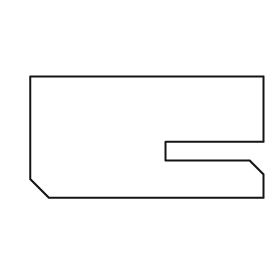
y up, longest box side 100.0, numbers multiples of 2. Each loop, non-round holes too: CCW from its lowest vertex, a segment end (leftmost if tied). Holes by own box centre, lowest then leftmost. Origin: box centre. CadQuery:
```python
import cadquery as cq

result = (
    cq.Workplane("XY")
    .moveTo(-42.0, -26.0)
    .lineTo(50.0, -26.0)
    .lineTo(50.0, -16.0)
    .lineTo(44.0, -10.0)
    .lineTo(8.0, -10.0)
    .lineTo(8.0, -2.0)
    .lineTo(50.0, -2.0)
    .lineTo(50.0, 26.0)
    .lineTo(-50.0, 26.0)
    .lineTo(-50.0, -18.0)
    .close()
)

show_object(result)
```